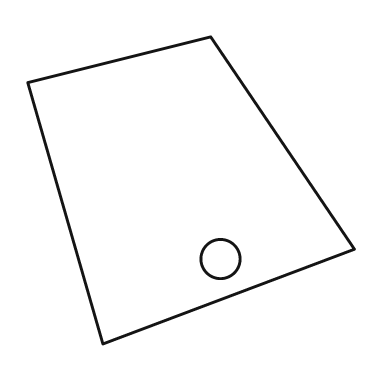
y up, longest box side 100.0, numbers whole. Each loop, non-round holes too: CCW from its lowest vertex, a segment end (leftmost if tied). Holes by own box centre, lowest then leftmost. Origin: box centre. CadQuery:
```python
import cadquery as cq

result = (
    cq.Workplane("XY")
    .moveTo(-27.0, -47.0)
    .lineTo(50.0, -18.0)
    .lineTo(6.0, 47.0)
    .lineTo(-50.0, 33.0)
    .close()
    .moveTo(9.0, -21.0)
    .circle(6.0)
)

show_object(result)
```